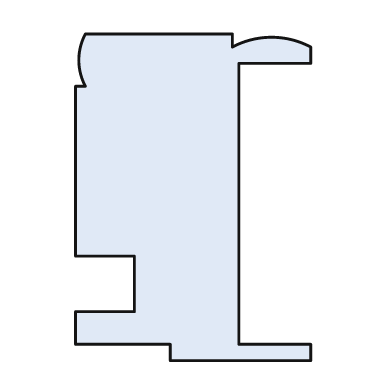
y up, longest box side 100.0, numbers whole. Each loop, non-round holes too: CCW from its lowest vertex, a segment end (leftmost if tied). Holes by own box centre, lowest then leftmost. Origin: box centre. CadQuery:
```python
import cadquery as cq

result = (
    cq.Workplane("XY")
    .moveTo(-7.0, -50.0)
    .lineTo(36.0, -50.0)
    .lineTo(36.0, -45.0)
    .lineTo(14.0, -45.0)
    .lineTo(14.0, 41.0)
    .lineTo(36.0, 41.0)
    .lineTo(36.0, 46.0)
    .threePointArc((24.0, 49.0), (12.0, 46.0))
    .lineTo(12.0, 50.0)
    .lineTo(-33.0, 50.0)
    .threePointArc((-35.0, 42.0), (-33.0, 34.0))
    .lineTo(-36.0, 34.0)
    .lineTo(-36.0, -18.0)
    .lineTo(-18.0, -18.0)
    .lineTo(-18.0, -35.0)
    .lineTo(-36.0, -35.0)
    .lineTo(-36.0, -45.0)
    .lineTo(-7.0, -45.0)
    .close()
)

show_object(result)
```